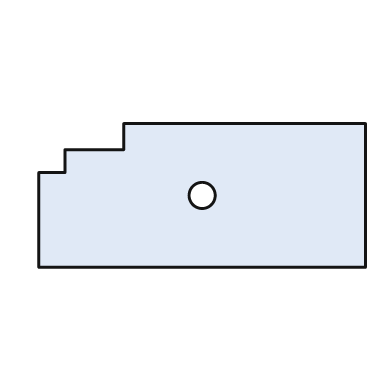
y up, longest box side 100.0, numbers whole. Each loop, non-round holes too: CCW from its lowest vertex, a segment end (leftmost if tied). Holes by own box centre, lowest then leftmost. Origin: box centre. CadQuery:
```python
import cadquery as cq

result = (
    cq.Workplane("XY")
    .moveTo(-50.0, -22.0)
    .lineTo(50.0, -22.0)
    .lineTo(50.0, 22.0)
    .lineTo(-24.0, 22.0)
    .lineTo(-24.0, 14.0)
    .lineTo(-42.0, 14.0)
    .lineTo(-42.0, 7.0)
    .lineTo(-50.0, 7.0)
    .close()
    .moveTo(0.0, 0.0)
    .circle(4.0)
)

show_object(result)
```